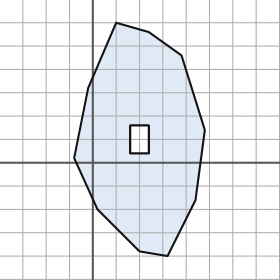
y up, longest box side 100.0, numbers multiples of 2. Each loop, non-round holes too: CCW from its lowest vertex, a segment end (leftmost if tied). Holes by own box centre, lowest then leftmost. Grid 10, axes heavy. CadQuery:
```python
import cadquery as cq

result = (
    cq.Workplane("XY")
    .moveTo(32.0, -40.0)
    .lineTo(44.0, -16.0)
    .lineTo(48.0, 14.0)
    .lineTo(38.0, 46.0)
    .lineTo(24.0, 56.0)
    .lineTo(10.0, 60.0)
    .lineTo(-2.0, 32.0)
    .lineTo(-8.0, 2.0)
    .lineTo(2.0, -20.0)
    .lineTo(20.0, -38.0)
    .close()
    .moveTo(16.0, 4.0)
    .lineTo(24.0, 4.0)
    .lineTo(24.0, 16.0)
    .lineTo(16.0, 16.0)
    .close()
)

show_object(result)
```